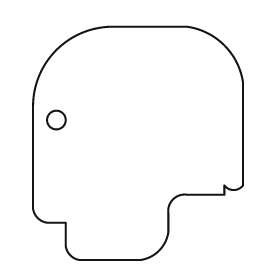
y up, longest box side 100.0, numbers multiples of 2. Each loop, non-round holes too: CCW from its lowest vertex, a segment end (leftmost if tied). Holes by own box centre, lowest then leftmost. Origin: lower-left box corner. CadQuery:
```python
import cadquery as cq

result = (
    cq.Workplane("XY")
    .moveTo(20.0, 0.0)
    .lineTo(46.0, 0.0)
    .threePointArc((54.0, 4.0), (58.0, 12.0))
    .lineTo(58.0, 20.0)
    .threePointArc((60.0, 26.0), (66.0, 28.0))
    .lineTo(82.0, 28.0)
    .lineTo(82.0, 32.0)
    .threePointArc((86.0, 30.0), (90.0, 32.0))
    .lineTo(90.0, 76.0)
    .threePointArc((82.0, 92.0), (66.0, 100.0))
    .lineTo(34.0, 100.0)
    .threePointArc((10.0, 90.0), (0.0, 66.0))
    .lineTo(0.0, 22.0)
    .threePointArc((2.0, 18.0), (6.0, 16.0))
    .lineTo(14.0, 16.0)
    .lineTo(14.0, 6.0)
    .threePointArc((16.0, 2.0), (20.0, 0.0))
    .close()
    .moveTo(10.0, 60.0)
    .circle(4.0)
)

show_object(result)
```